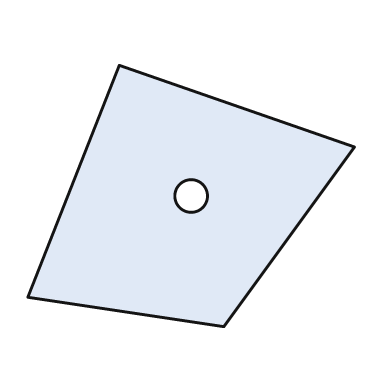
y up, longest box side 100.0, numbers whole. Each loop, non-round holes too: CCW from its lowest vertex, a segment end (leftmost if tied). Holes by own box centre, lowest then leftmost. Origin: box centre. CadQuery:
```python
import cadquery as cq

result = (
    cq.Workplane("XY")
    .moveTo(10.0, -40.0)
    .lineTo(50.0, 15.0)
    .lineTo(-22.0, 40.0)
    .lineTo(-50.0, -31.0)
    .close()
    .moveTo(0.0, 0.0)
    .circle(5.0)
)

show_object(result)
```